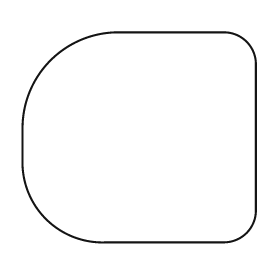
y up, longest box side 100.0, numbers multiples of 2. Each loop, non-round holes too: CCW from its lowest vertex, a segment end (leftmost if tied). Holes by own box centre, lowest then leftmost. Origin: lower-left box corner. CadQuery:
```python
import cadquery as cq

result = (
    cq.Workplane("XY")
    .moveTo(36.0, 0.0)
    .lineTo(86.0, 0.0)
    .threePointArc((96.0, 4.0), (100.0, 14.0))
    .lineTo(100.0, 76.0)
    .threePointArc((96.0, 86.0), (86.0, 90.0))
    .lineTo(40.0, 90.0)
    .threePointArc((12.0, 78.0), (0.0, 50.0))
    .lineTo(0.0, 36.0)
    .threePointArc((10.0, 10.0), (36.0, 0.0))
    .close()
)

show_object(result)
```